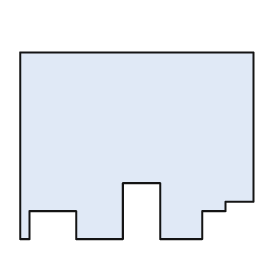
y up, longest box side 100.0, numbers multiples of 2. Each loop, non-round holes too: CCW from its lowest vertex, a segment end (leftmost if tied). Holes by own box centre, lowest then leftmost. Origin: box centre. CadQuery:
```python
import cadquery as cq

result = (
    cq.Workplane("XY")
    .moveTo(-50.0, -40.0)
    .lineTo(-46.0, -40.0)
    .lineTo(-46.0, -28.0)
    .lineTo(-26.0, -28.0)
    .lineTo(-26.0, -40.0)
    .lineTo(-6.0, -40.0)
    .lineTo(-6.0, -16.0)
    .lineTo(10.0, -16.0)
    .lineTo(10.0, -40.0)
    .lineTo(28.0, -40.0)
    .lineTo(28.0, -28.0)
    .lineTo(38.0, -28.0)
    .lineTo(38.0, -24.0)
    .lineTo(50.0, -24.0)
    .lineTo(50.0, 40.0)
    .lineTo(-50.0, 40.0)
    .close()
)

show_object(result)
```